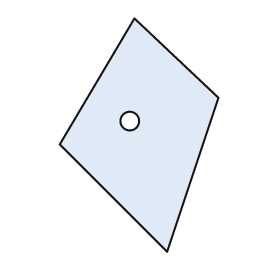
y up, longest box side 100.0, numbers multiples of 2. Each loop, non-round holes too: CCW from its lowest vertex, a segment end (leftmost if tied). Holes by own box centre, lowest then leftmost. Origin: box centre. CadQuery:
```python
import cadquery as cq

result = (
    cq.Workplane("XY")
    .moveTo(12.0, -50.0)
    .lineTo(34.0, 16.0)
    .lineTo(-2.0, 50.0)
    .lineTo(-34.0, -4.0)
    .close()
    .moveTo(-4.0, 6.0)
    .circle(4.0)
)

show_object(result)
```